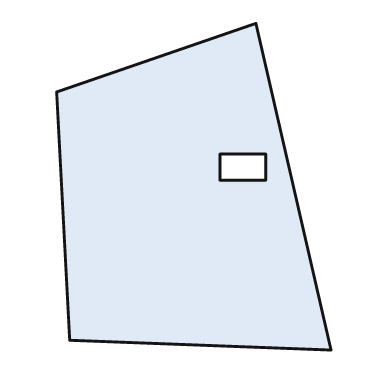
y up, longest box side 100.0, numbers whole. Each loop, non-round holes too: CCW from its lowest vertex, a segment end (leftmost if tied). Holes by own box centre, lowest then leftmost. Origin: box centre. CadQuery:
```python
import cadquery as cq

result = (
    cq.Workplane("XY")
    .moveTo(42.0, -50.0)
    .lineTo(19.0, 50.0)
    .lineTo(-42.0, 29.0)
    .lineTo(-38.0, -47.0)
    .close()
    .moveTo(8.0, 2.0)
    .lineTo(22.0, 2.0)
    .lineTo(22.0, 10.0)
    .lineTo(8.0, 10.0)
    .close()
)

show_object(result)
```